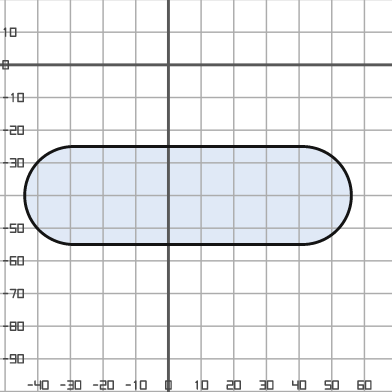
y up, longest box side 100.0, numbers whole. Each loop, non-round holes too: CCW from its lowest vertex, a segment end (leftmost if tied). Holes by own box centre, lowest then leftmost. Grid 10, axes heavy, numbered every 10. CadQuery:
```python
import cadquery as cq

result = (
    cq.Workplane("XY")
    .moveTo(-29.0, -55.0)
    .lineTo(41.0, -55.0)
    .threePointArc((56.0, -40.0), (41.0, -25.0))
    .lineTo(-29.0, -25.0)
    .threePointArc((-44.0, -40.0), (-29.0, -55.0))
    .close()
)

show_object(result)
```